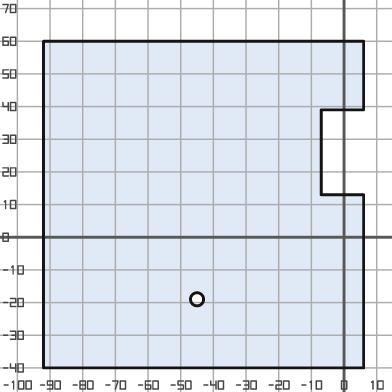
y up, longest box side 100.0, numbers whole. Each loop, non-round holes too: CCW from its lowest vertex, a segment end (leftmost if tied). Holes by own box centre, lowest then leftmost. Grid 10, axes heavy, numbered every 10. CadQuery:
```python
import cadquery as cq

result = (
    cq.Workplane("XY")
    .moveTo(-92.0, -40.0)
    .lineTo(6.0, -40.0)
    .lineTo(6.0, 13.0)
    .lineTo(-7.0, 13.0)
    .lineTo(-7.0, 39.0)
    .lineTo(6.0, 39.0)
    .lineTo(6.0, 60.0)
    .lineTo(-92.0, 60.0)
    .close()
    .moveTo(-45.0, -19.0)
    .circle(2.0)
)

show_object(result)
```